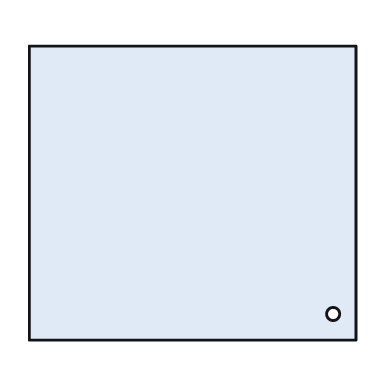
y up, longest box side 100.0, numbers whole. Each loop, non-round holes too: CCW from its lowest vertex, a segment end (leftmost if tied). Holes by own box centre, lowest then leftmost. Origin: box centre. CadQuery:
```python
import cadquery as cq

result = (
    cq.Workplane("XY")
    .moveTo(-50.0, -45.0)
    .lineTo(50.0, -45.0)
    .lineTo(50.0, 45.0)
    .lineTo(-50.0, 45.0)
    .close()
    .moveTo(43.0, -37.0)
    .circle(2.0)
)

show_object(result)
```